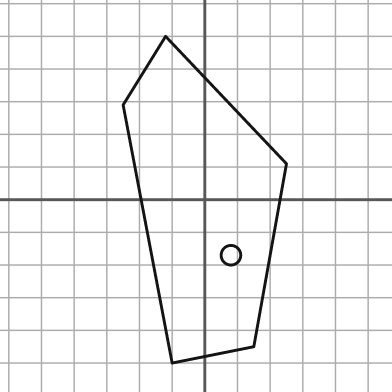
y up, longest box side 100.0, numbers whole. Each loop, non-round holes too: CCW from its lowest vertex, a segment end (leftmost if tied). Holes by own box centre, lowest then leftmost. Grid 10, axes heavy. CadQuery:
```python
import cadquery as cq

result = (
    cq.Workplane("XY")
    .moveTo(-10.0, -50.0)
    .lineTo(15.0, -45.0)
    .lineTo(25.0, 11.0)
    .lineTo(-12.0, 50.0)
    .lineTo(-25.0, 29.0)
    .close()
    .moveTo(8.0, -17.0)
    .circle(3.0)
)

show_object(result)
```